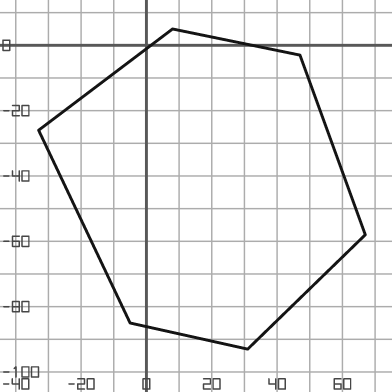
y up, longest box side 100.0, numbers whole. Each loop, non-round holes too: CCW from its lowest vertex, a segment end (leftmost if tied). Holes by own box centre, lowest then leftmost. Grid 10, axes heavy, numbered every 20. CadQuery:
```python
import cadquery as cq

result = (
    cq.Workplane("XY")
    .moveTo(31.0, -93.0)
    .lineTo(67.0, -58.0)
    .lineTo(47.0, -3.0)
    .lineTo(8.0, 5.0)
    .lineTo(-33.0, -26.0)
    .lineTo(-5.0, -85.0)
    .close()
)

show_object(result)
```